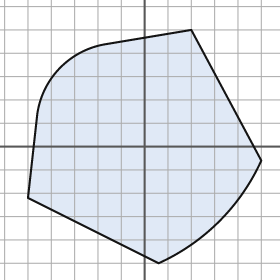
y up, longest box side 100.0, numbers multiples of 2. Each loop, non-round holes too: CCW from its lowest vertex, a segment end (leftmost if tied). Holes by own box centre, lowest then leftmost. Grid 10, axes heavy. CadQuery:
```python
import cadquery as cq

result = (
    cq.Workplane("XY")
    .moveTo(6.0, -50.0)
    .threePointArc((32.0, -32.0), (50.0, -6.0))
    .lineTo(20.0, 50.0)
    .lineTo(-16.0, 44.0)
    .threePointArc((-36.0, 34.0), (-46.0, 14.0))
    .lineTo(-50.0, -22.0)
    .close()
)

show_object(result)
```